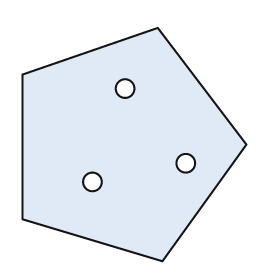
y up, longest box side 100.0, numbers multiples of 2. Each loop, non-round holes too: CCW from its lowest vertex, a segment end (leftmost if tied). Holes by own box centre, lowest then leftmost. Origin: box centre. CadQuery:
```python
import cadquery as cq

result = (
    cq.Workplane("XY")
    .moveTo(12.0, -50.0)
    .lineTo(48.0, 0.0)
    .lineTo(10.0, 50.0)
    .lineTo(-48.0, 30.0)
    .lineTo(-48.0, -32.0)
    .close()
    .moveTo(-18.0, -16.0)
    .circle(4.0)
    .moveTo(22.0, -8.0)
    .circle(4.0)
    .moveTo(-4.0, 24.0)
    .circle(4.0)
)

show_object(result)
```